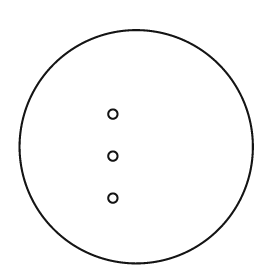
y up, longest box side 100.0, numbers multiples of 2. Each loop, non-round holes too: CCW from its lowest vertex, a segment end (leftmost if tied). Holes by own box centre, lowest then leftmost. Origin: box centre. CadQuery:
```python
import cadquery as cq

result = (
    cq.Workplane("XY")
    .moveTo(0.0, 0.0)
    .circle(50.0)
    .moveTo(-10.0, -22.0)
    .circle(2.0)
    .moveTo(-10.0, -4.0)
    .circle(2.0)
    .moveTo(-10.0, 14.0)
    .circle(2.0)
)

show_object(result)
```